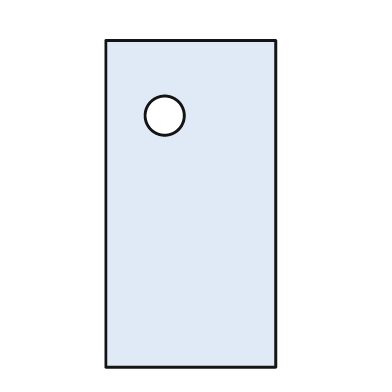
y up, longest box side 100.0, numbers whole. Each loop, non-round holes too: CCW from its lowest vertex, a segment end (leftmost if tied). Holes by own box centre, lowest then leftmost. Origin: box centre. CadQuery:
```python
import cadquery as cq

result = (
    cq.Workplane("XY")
    .moveTo(-26.0, -50.0)
    .lineTo(26.0, -50.0)
    .lineTo(26.0, 50.0)
    .lineTo(-26.0, 50.0)
    .close()
    .moveTo(-8.0, 27.0)
    .circle(6.0)
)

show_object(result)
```